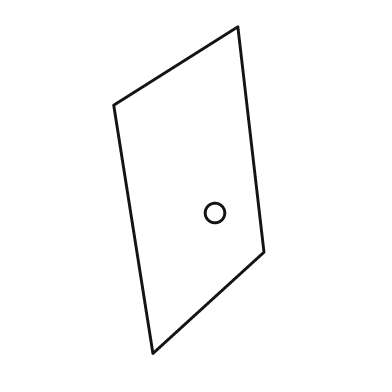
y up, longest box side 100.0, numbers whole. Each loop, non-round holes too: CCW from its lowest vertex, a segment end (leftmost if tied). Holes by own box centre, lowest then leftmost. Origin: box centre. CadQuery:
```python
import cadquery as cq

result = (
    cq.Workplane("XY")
    .moveTo(-11.0, -50.0)
    .lineTo(23.0, -19.0)
    .lineTo(15.0, 50.0)
    .lineTo(-23.0, 26.0)
    .close()
    .moveTo(8.0, -7.0)
    .circle(3.0)
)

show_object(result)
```